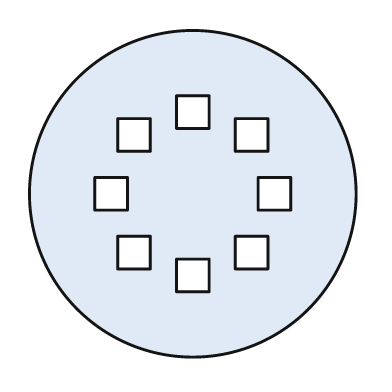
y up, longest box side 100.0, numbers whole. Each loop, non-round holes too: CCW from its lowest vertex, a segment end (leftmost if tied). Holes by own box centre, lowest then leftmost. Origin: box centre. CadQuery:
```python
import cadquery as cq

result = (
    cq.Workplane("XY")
    .moveTo(0.0, 0.0)
    .circle(50.0)
    .moveTo(-5.0, -30.0)
    .lineTo(5.0, -30.0)
    .lineTo(5.0, -20.0)
    .lineTo(-5.0, -20.0)
    .close()
    .moveTo(-23.0, -23.0)
    .lineTo(-13.0, -23.0)
    .lineTo(-13.0, -13.0)
    .lineTo(-23.0, -13.0)
    .close()
    .moveTo(13.0, -23.0)
    .lineTo(23.0, -23.0)
    .lineTo(23.0, -13.0)
    .lineTo(13.0, -13.0)
    .close()
    .moveTo(-30.0, -5.0)
    .lineTo(-20.0, -5.0)
    .lineTo(-20.0, 5.0)
    .lineTo(-30.0, 5.0)
    .close()
    .moveTo(20.0, -5.0)
    .lineTo(30.0, -5.0)
    .lineTo(30.0, 5.0)
    .lineTo(20.0, 5.0)
    .close()
    .moveTo(-23.0, 13.0)
    .lineTo(-13.0, 13.0)
    .lineTo(-13.0, 23.0)
    .lineTo(-23.0, 23.0)
    .close()
    .moveTo(13.0, 13.0)
    .lineTo(23.0, 13.0)
    .lineTo(23.0, 23.0)
    .lineTo(13.0, 23.0)
    .close()
    .moveTo(-5.0, 20.0)
    .lineTo(5.0, 20.0)
    .lineTo(5.0, 30.0)
    .lineTo(-5.0, 30.0)
    .close()
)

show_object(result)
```